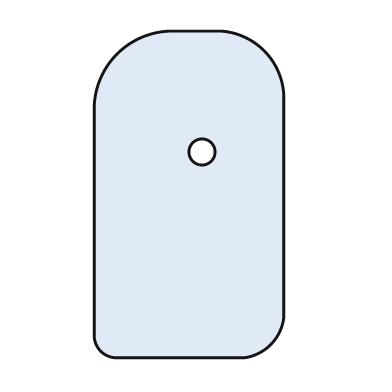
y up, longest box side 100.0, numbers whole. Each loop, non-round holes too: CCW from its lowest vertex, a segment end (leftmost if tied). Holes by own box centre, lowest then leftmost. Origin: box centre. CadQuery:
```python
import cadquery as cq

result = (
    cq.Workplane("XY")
    .moveTo(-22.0, -50.0)
    .lineTo(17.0, -50.0)
    .threePointArc((25.0, -46.0), (29.0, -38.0))
    .lineTo(29.0, 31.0)
    .threePointArc((23.0, 44.0), (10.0, 50.0))
    .lineTo(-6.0, 50.0)
    .threePointArc((-22.0, 43.0), (-29.0, 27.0))
    .lineTo(-29.0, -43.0)
    .threePointArc((-27.0, -48.0), (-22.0, -50.0))
    .close()
    .moveTo(4.0, 13.0)
    .circle(4.0)
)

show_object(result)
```